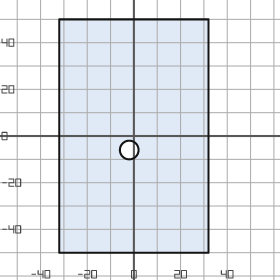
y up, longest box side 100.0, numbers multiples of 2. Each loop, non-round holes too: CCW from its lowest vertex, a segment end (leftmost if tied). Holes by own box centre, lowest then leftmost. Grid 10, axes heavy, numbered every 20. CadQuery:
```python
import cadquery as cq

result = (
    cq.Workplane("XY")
    .moveTo(-32.0, -50.0)
    .lineTo(32.0, -50.0)
    .lineTo(32.0, 50.0)
    .lineTo(-32.0, 50.0)
    .close()
    .moveTo(-2.0, -6.0)
    .circle(4.0)
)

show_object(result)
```